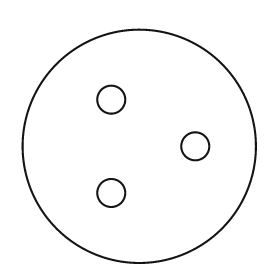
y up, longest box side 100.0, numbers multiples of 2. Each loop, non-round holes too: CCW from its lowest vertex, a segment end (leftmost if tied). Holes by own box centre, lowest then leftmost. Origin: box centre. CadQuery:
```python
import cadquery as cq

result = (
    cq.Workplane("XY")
    .moveTo(0.0, 0.0)
    .circle(50.0)
    .moveTo(-12.0, -20.0)
    .circle(6.0)
    .moveTo(24.0, 0.0)
    .circle(6.0)
    .moveTo(-12.0, 20.0)
    .circle(6.0)
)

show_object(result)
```